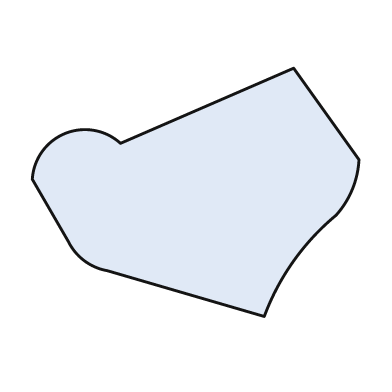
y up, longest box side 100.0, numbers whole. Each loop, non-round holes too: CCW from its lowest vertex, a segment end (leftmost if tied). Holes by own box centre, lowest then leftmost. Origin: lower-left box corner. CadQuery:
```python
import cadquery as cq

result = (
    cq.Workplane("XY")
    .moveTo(71.0, 0.0)
    .threePointArc((80.0, 17.0), (93.0, 31.0))
    .threePointArc((98.0, 39.0), (100.0, 48.0))
    .lineTo(80.0, 76.0)
    .lineTo(27.0, 53.0)
    .threePointArc((10.0, 56.0), (0.0, 42.0))
    .lineTo(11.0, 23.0)
    .threePointArc((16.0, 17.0), (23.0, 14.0))
    .close()
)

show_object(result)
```